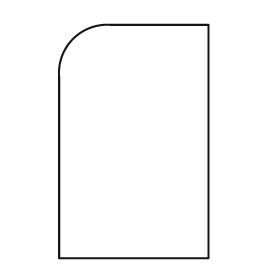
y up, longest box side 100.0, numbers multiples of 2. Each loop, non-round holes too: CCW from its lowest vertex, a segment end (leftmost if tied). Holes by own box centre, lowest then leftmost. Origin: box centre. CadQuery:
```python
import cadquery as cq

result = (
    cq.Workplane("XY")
    .moveTo(-32.0, -50.0)
    .lineTo(32.0, -50.0)
    .lineTo(32.0, 50.0)
    .lineTo(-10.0, 50.0)
    .threePointArc((-26.0, 44.0), (-32.0, 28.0))
    .close()
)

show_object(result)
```